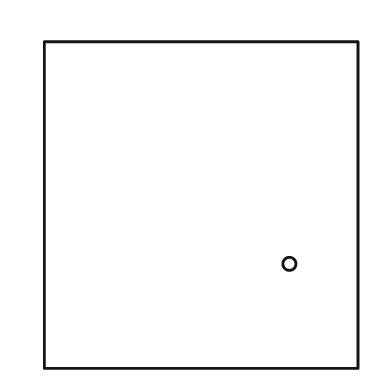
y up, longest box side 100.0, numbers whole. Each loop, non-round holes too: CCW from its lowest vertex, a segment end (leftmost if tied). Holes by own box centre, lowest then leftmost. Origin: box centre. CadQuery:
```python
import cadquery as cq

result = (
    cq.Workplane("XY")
    .moveTo(-48.0, -50.0)
    .lineTo(48.0, -50.0)
    .lineTo(48.0, 50.0)
    .lineTo(-48.0, 50.0)
    .close()
    .moveTo(27.0, -18.0)
    .circle(2.0)
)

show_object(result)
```